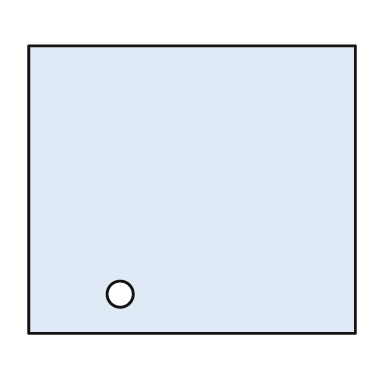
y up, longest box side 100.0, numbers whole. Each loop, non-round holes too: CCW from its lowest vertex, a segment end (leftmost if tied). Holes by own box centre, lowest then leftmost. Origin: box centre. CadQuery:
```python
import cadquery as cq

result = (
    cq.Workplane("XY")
    .moveTo(-50.0, -44.0)
    .lineTo(50.0, -44.0)
    .lineTo(50.0, 44.0)
    .lineTo(-50.0, 44.0)
    .close()
    .moveTo(-22.0, -32.0)
    .circle(4.0)
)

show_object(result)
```